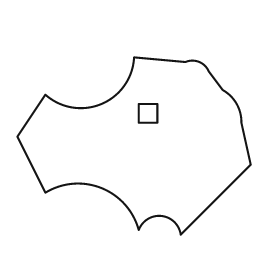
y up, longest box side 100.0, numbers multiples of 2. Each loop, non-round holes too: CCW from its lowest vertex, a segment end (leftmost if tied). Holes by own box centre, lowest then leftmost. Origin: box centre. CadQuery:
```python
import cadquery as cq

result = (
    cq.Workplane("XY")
    .moveTo(20.0, -38.0)
    .lineTo(50.0, -8.0)
    .lineTo(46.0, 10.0)
    .threePointArc((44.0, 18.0), (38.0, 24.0))
    .lineTo(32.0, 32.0)
    .threePointArc((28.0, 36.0), (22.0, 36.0))
    .lineTo(0.0, 38.0)
    .threePointArc((-14.0, 18.0), (-38.0, 22.0))
    .lineTo(-50.0, 4.0)
    .lineTo(-38.0, -20.0)
    .threePointArc((-14.0, -18.0), (2.0, -36.0))
    .threePointArc((12.0, -30.0), (20.0, -38.0))
    .close()
    .moveTo(2.0, 10.0)
    .lineTo(10.0, 10.0)
    .lineTo(10.0, 18.0)
    .lineTo(2.0, 18.0)
    .close()
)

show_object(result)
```